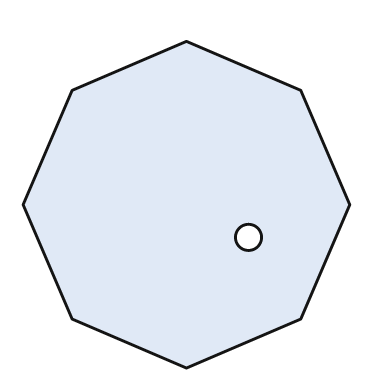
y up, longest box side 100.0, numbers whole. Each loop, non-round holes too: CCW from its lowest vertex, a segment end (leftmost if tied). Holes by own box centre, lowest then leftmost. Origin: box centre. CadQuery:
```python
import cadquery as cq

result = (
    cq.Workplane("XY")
    .moveTo(0.0, -50.0)
    .lineTo(35.0, -35.0)
    .lineTo(50.0, 0.0)
    .lineTo(35.0, 35.0)
    .lineTo(0.0, 50.0)
    .lineTo(-35.0, 35.0)
    .lineTo(-50.0, 0.0)
    .lineTo(-35.0, -35.0)
    .close()
    .moveTo(19.0, -10.0)
    .circle(4.0)
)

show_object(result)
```